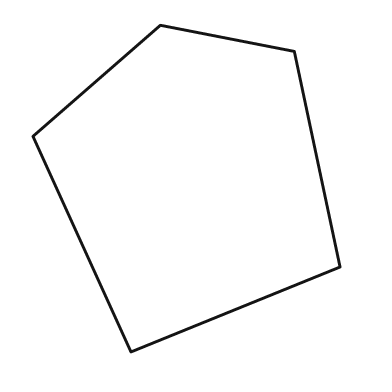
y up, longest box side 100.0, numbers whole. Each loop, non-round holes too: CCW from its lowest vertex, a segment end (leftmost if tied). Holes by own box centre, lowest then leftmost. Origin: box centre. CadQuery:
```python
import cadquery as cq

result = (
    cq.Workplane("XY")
    .moveTo(-17.0, -50.0)
    .lineTo(47.0, -24.0)
    .lineTo(33.0, 42.0)
    .lineTo(-8.0, 50.0)
    .lineTo(-47.0, 16.0)
    .close()
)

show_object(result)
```